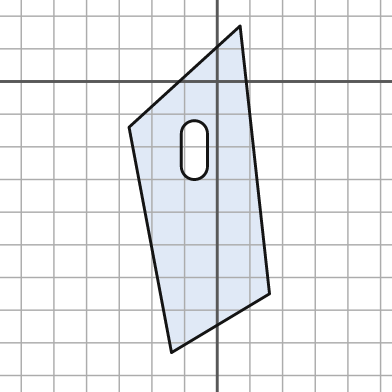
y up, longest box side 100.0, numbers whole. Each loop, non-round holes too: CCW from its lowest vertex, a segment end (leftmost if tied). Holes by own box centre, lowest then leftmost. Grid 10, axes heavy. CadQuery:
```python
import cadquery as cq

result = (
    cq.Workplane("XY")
    .moveTo(-14.0, -83.0)
    .lineTo(16.0, -65.0)
    .lineTo(7.0, 17.0)
    .lineTo(-27.0, -14.0)
    .close()
    .moveTo(-11.0, -26.0)
    .threePointArc((-7.0, -30.0), (-3.0, -26.0))
    .lineTo(-3.0, -16.0)
    .threePointArc((-7.0, -12.0), (-11.0, -16.0))
    .close()
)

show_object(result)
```